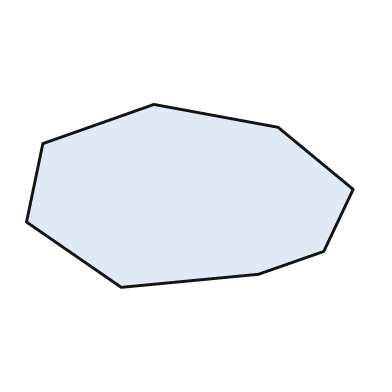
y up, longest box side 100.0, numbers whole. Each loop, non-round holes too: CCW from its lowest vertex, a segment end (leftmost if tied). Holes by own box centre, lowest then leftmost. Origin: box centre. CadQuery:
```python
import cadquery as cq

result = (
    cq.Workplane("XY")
    .moveTo(-21.0, -28.0)
    .lineTo(21.0, -24.0)
    .lineTo(41.0, -17.0)
    .lineTo(50.0, 2.0)
    .lineTo(27.0, 21.0)
    .lineTo(-11.0, 28.0)
    .lineTo(-45.0, 16.0)
    .lineTo(-50.0, -8.0)
    .close()
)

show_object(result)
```